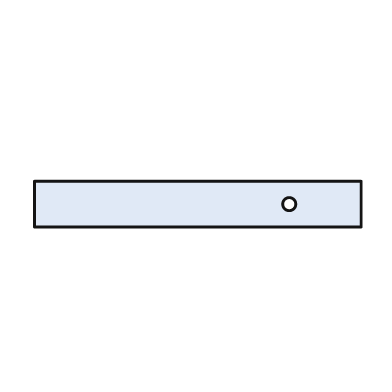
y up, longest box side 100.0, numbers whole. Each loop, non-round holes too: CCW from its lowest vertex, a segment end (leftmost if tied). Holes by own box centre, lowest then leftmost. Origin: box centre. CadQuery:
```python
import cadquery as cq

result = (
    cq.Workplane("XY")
    .moveTo(-50.0, -7.0)
    .lineTo(50.0, -7.0)
    .lineTo(50.0, 7.0)
    .lineTo(-50.0, 7.0)
    .close()
    .moveTo(28.0, 0.0)
    .circle(2.0)
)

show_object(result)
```